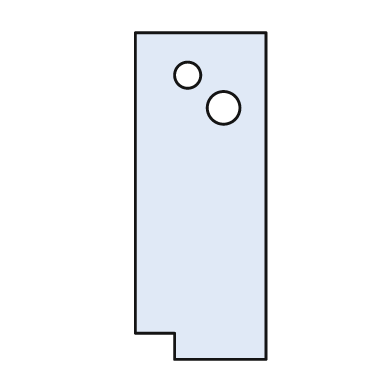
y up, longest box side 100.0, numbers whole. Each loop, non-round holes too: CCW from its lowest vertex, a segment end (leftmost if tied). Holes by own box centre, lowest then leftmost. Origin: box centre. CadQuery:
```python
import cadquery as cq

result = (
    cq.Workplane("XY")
    .moveTo(-8.0, -50.0)
    .lineTo(20.0, -50.0)
    .lineTo(20.0, 50.0)
    .lineTo(-20.0, 50.0)
    .lineTo(-20.0, -42.0)
    .lineTo(-8.0, -42.0)
    .close()
    .moveTo(7.0, 27.0)
    .circle(5.0)
    .moveTo(-4.0, 37.0)
    .circle(4.0)
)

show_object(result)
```